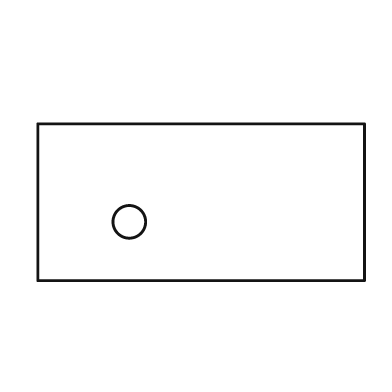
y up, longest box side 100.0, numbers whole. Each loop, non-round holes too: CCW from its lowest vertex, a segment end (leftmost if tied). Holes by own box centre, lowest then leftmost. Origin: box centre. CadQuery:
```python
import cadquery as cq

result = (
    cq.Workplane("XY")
    .moveTo(-50.0, -24.0)
    .lineTo(50.0, -24.0)
    .lineTo(50.0, 24.0)
    .lineTo(-50.0, 24.0)
    .close()
    .moveTo(-22.0, -6.0)
    .circle(5.0)
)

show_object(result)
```